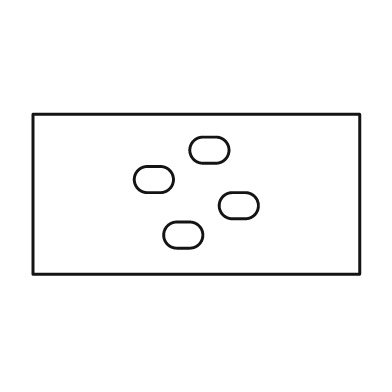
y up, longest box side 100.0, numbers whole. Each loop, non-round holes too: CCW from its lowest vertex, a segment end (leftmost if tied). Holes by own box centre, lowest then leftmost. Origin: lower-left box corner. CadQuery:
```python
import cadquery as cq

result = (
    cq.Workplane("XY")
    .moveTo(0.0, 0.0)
    .lineTo(100.0, 0.0)
    .lineTo(100.0, 49.0)
    .lineTo(0.0, 49.0)
    .close()
    .moveTo(44.0, 8.0)
    .lineTo(48.0, 8.0)
    .threePointArc((52.0, 12.0), (48.0, 16.0))
    .lineTo(44.0, 16.0)
    .threePointArc((40.0, 12.0), (44.0, 8.0))
    .close()
    .moveTo(61.0, 17.0)
    .lineTo(65.0, 17.0)
    .threePointArc((69.0, 21.0), (65.0, 25.0))
    .lineTo(61.0, 25.0)
    .threePointArc((57.0, 21.0), (61.0, 17.0))
    .close()
    .moveTo(35.0, 25.0)
    .lineTo(39.0, 25.0)
    .threePointArc((43.0, 29.0), (39.0, 33.0))
    .lineTo(35.0, 33.0)
    .threePointArc((31.0, 29.0), (35.0, 25.0))
    .close()
    .moveTo(52.0, 34.0)
    .lineTo(56.0, 34.0)
    .threePointArc((60.0, 38.0), (56.0, 42.0))
    .lineTo(52.0, 42.0)
    .threePointArc((48.0, 38.0), (52.0, 34.0))
    .close()
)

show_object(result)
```